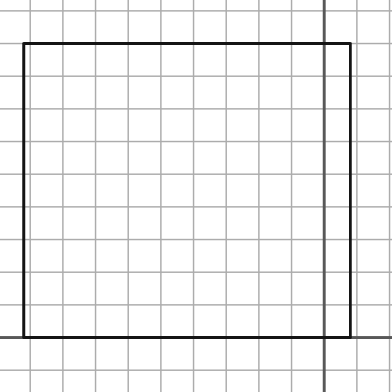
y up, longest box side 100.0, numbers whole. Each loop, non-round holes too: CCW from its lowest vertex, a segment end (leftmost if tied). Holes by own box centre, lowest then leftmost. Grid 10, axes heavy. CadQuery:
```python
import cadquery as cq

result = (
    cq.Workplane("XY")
    .moveTo(-92.0, 0.0)
    .lineTo(8.0, 0.0)
    .lineTo(8.0, 90.0)
    .lineTo(-92.0, 90.0)
    .close()
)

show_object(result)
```